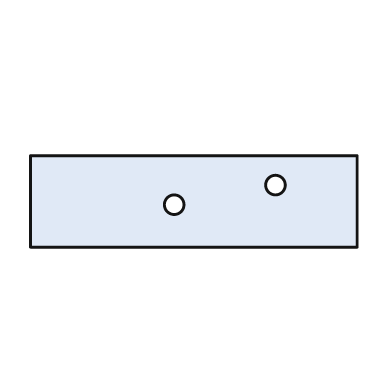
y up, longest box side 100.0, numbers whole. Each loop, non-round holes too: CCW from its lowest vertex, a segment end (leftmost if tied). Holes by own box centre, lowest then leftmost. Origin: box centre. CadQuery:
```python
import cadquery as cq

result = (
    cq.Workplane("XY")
    .moveTo(-50.0, -14.0)
    .lineTo(50.0, -14.0)
    .lineTo(50.0, 14.0)
    .lineTo(-50.0, 14.0)
    .close()
    .moveTo(-6.0, -1.0)
    .circle(3.0)
    .moveTo(25.0, 5.0)
    .circle(3.0)
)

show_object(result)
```